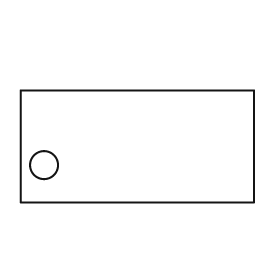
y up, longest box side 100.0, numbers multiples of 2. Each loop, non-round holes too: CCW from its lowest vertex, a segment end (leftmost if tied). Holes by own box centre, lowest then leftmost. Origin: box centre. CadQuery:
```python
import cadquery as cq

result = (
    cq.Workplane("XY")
    .moveTo(-50.0, -24.0)
    .lineTo(50.0, -24.0)
    .lineTo(50.0, 24.0)
    .lineTo(-50.0, 24.0)
    .close()
    .moveTo(-40.0, -8.0)
    .circle(6.0)
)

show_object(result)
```